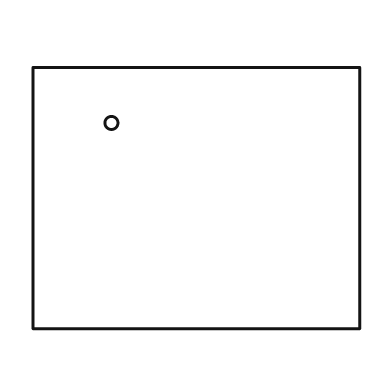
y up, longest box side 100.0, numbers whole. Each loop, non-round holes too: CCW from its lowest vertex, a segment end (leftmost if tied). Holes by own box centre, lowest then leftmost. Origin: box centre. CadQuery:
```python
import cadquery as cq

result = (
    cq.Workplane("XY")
    .moveTo(-50.0, -40.0)
    .lineTo(50.0, -40.0)
    .lineTo(50.0, 40.0)
    .lineTo(-50.0, 40.0)
    .close()
    .moveTo(-26.0, 23.0)
    .circle(2.0)
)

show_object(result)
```